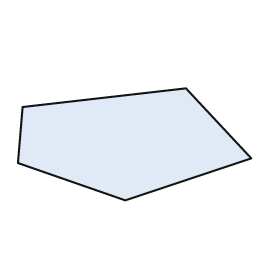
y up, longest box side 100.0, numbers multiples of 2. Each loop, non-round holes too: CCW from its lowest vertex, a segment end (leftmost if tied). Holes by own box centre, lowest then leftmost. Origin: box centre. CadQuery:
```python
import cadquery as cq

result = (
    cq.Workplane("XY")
    .moveTo(-4.0, -24.0)
    .lineTo(50.0, -6.0)
    .lineTo(22.0, 24.0)
    .lineTo(-48.0, 16.0)
    .lineTo(-50.0, -8.0)
    .close()
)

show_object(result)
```